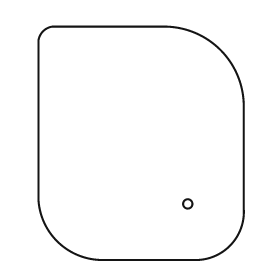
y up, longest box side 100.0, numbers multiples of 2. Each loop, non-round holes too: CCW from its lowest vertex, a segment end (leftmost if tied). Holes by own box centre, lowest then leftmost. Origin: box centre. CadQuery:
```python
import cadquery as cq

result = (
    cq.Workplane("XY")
    .moveTo(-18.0, -50.0)
    .lineTo(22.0, -50.0)
    .threePointArc((38.0, -44.0), (44.0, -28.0))
    .lineTo(44.0, 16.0)
    .threePointArc((34.0, 40.0), (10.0, 50.0))
    .lineTo(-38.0, 50.0)
    .threePointArc((-42.0, 48.0), (-44.0, 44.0))
    .lineTo(-44.0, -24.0)
    .threePointArc((-36.0, -42.0), (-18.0, -50.0))
    .close()
    .moveTo(20.0, -26.0)
    .circle(2.0)
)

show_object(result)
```